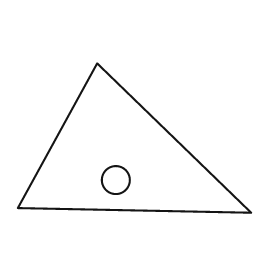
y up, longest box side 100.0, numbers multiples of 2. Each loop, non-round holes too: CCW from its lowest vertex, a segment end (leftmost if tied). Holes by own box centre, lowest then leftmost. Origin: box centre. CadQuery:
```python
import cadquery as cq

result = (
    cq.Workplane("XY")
    .moveTo(50.0, -32.0)
    .lineTo(-16.0, 32.0)
    .lineTo(-50.0, -30.0)
    .close()
    .moveTo(-8.0, -18.0)
    .circle(6.0)
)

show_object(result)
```